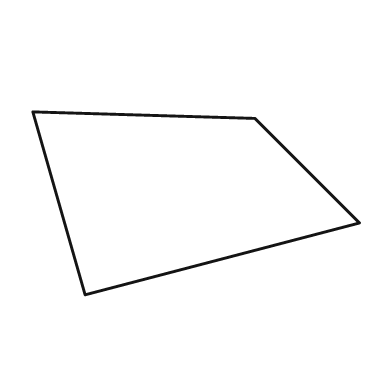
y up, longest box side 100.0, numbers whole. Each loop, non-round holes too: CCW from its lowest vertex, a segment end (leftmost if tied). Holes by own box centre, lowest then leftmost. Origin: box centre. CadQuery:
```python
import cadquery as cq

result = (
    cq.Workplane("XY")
    .moveTo(-34.0, -28.0)
    .lineTo(50.0, -6.0)
    .lineTo(18.0, 26.0)
    .lineTo(-50.0, 28.0)
    .close()
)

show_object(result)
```